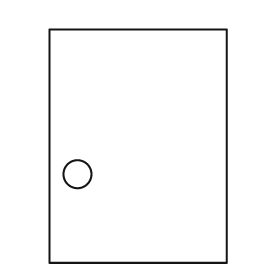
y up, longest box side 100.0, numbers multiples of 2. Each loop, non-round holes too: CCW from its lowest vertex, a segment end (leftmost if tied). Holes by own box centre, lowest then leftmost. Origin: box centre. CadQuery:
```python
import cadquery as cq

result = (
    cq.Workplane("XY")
    .moveTo(-38.0, -50.0)
    .lineTo(38.0, -50.0)
    .lineTo(38.0, 50.0)
    .lineTo(-38.0, 50.0)
    .close()
    .moveTo(-26.0, -12.0)
    .circle(6.0)
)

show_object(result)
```